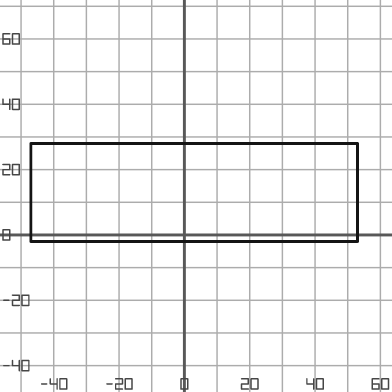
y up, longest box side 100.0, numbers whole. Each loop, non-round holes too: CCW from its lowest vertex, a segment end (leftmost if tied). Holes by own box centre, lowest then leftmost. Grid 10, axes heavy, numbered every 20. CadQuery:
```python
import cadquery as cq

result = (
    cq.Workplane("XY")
    .moveTo(-47.0, -2.0)
    .lineTo(53.0, -2.0)
    .lineTo(53.0, 28.0)
    .lineTo(-47.0, 28.0)
    .close()
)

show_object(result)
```